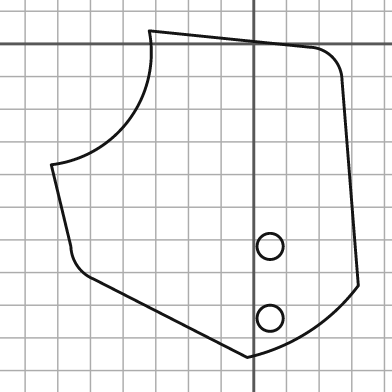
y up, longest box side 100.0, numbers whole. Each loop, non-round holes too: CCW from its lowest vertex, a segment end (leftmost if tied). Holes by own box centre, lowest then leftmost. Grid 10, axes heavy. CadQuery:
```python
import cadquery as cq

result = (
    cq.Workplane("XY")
    .moveTo(-2.0, -96.0)
    .threePointArc((17.0, -88.0), (32.0, -74.0))
    .lineTo(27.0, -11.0)
    .threePointArc((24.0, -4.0), (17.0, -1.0))
    .lineTo(-32.0, 4.0)
    .threePointArc((-38.0, -23.0), (-62.0, -37.0))
    .lineTo(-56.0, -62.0)
    .threePointArc((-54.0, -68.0), (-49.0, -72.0))
    .close()
    .moveTo(5.0, -84.0)
    .circle(4.0)
    .moveTo(5.0, -62.0)
    .circle(4.0)
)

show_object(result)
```